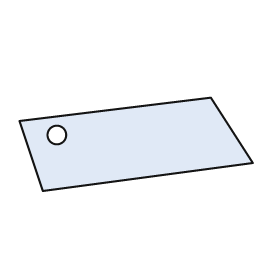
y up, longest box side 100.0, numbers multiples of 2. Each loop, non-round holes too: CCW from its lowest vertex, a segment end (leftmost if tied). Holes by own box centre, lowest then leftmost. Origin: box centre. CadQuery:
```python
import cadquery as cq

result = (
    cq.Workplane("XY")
    .moveTo(-40.0, -20.0)
    .lineTo(50.0, -8.0)
    .lineTo(32.0, 20.0)
    .lineTo(-50.0, 10.0)
    .close()
    .moveTo(-34.0, 4.0)
    .circle(4.0)
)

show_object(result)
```